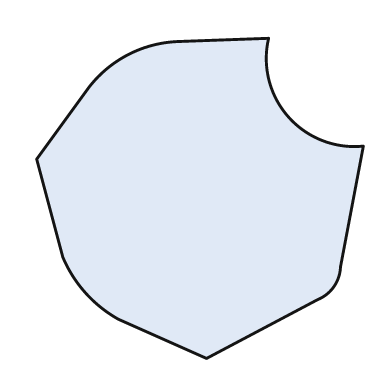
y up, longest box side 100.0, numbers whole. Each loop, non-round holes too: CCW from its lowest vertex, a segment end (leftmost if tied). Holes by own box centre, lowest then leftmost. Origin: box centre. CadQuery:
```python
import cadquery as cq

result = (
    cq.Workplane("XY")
    .moveTo(2.0, -49.0)
    .lineTo(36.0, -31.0)
    .threePointArc((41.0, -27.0), (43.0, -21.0))
    .lineTo(50.0, 16.0)
    .threePointArc((27.0, 25.0), (21.0, 49.0))
    .lineTo(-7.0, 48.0)
    .threePointArc((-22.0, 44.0), (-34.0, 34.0))
    .lineTo(-50.0, 12.0)
    .lineTo(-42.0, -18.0)
    .threePointArc((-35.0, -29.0), (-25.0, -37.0))
    .close()
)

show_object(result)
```